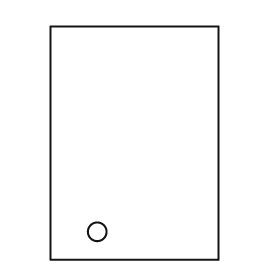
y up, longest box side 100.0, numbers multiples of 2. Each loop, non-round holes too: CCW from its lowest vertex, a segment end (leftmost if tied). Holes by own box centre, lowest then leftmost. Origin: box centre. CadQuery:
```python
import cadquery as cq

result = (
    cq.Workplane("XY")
    .moveTo(-36.0, -50.0)
    .lineTo(36.0, -50.0)
    .lineTo(36.0, 50.0)
    .lineTo(-36.0, 50.0)
    .close()
    .moveTo(-16.0, -38.0)
    .circle(4.0)
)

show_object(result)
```